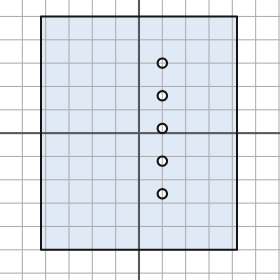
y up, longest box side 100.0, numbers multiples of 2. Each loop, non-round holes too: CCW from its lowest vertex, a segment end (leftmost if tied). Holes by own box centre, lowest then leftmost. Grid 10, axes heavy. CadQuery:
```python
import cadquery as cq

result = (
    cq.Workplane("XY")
    .moveTo(-42.0, -50.0)
    .lineTo(42.0, -50.0)
    .lineTo(42.0, 50.0)
    .lineTo(-42.0, 50.0)
    .close()
    .moveTo(10.0, -26.0)
    .circle(2.0)
    .moveTo(10.0, -12.0)
    .circle(2.0)
    .moveTo(10.0, 2.0)
    .circle(2.0)
    .moveTo(10.0, 16.0)
    .circle(2.0)
    .moveTo(10.0, 30.0)
    .circle(2.0)
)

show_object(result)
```